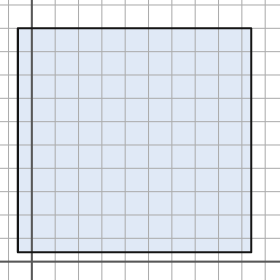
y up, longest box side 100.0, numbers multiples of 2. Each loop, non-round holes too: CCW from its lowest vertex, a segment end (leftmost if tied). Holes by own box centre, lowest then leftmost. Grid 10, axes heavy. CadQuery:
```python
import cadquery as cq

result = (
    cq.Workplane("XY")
    .moveTo(-6.0, 4.0)
    .lineTo(94.0, 4.0)
    .lineTo(94.0, 100.0)
    .lineTo(-6.0, 100.0)
    .close()
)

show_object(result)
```